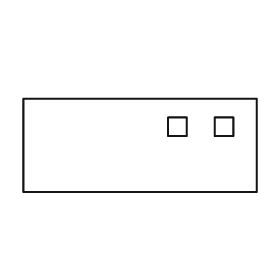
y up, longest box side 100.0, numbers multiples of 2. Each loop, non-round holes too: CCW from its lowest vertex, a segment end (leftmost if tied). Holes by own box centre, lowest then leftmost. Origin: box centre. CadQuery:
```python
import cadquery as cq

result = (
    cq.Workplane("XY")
    .moveTo(-50.0, -20.0)
    .lineTo(50.0, -20.0)
    .lineTo(50.0, 20.0)
    .lineTo(-50.0, 20.0)
    .close()
    .moveTo(12.0, 4.0)
    .lineTo(20.0, 4.0)
    .lineTo(20.0, 12.0)
    .lineTo(12.0, 12.0)
    .close()
    .moveTo(32.0, 4.0)
    .lineTo(40.0, 4.0)
    .lineTo(40.0, 12.0)
    .lineTo(32.0, 12.0)
    .close()
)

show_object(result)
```